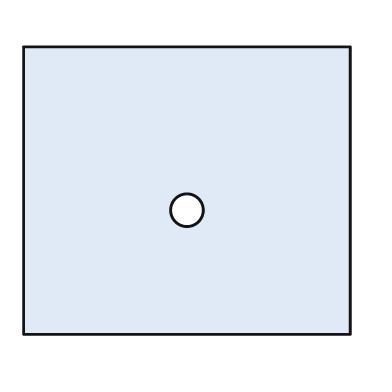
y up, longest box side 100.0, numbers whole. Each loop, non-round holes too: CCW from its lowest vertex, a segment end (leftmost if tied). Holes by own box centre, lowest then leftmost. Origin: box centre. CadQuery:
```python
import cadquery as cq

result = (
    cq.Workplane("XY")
    .moveTo(-50.0, -44.0)
    .lineTo(50.0, -44.0)
    .lineTo(50.0, 44.0)
    .lineTo(-50.0, 44.0)
    .close()
    .moveTo(0.0, -6.0)
    .circle(5.0)
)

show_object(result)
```